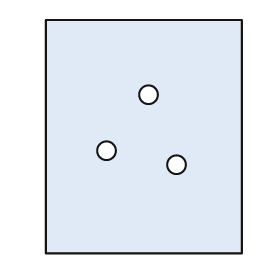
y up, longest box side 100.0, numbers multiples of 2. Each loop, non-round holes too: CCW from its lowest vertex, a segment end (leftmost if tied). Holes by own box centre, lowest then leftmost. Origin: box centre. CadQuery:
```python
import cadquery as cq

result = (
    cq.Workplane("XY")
    .moveTo(-42.0, -50.0)
    .lineTo(42.0, -50.0)
    .lineTo(42.0, 50.0)
    .lineTo(-42.0, 50.0)
    .close()
    .moveTo(14.0, -12.0)
    .circle(4.0)
    .moveTo(-16.0, -6.0)
    .circle(4.0)
    .moveTo(2.0, 18.0)
    .circle(4.0)
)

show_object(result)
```